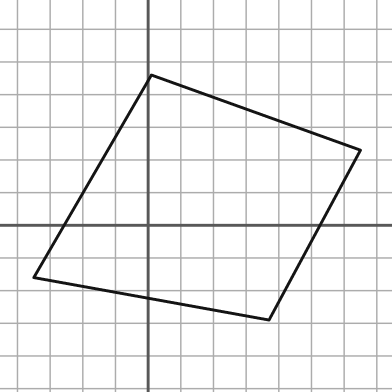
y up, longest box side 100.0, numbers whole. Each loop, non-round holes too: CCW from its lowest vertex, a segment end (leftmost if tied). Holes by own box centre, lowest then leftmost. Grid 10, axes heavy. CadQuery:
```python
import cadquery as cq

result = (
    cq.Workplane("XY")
    .moveTo(37.0, -29.0)
    .lineTo(65.0, 23.0)
    .lineTo(1.0, 46.0)
    .lineTo(-35.0, -16.0)
    .close()
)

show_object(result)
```